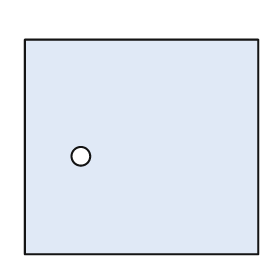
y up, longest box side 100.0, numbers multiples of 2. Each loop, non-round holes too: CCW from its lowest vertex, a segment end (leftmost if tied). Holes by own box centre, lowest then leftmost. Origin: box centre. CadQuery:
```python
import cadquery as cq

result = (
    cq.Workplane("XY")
    .moveTo(-50.0, -46.0)
    .lineTo(50.0, -46.0)
    .lineTo(50.0, 46.0)
    .lineTo(-50.0, 46.0)
    .close()
    .moveTo(-26.0, -4.0)
    .circle(4.0)
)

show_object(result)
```